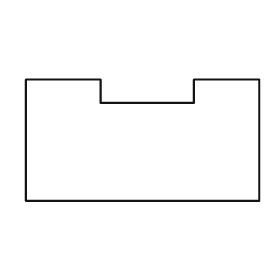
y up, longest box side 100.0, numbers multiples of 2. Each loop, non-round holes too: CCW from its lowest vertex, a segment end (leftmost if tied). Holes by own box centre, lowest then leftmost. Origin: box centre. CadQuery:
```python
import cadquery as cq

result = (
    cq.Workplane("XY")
    .moveTo(-50.0, -26.0)
    .lineTo(50.0, -26.0)
    .lineTo(50.0, 26.0)
    .lineTo(22.0, 26.0)
    .lineTo(22.0, 16.0)
    .lineTo(-18.0, 16.0)
    .lineTo(-18.0, 26.0)
    .lineTo(-50.0, 26.0)
    .close()
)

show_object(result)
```